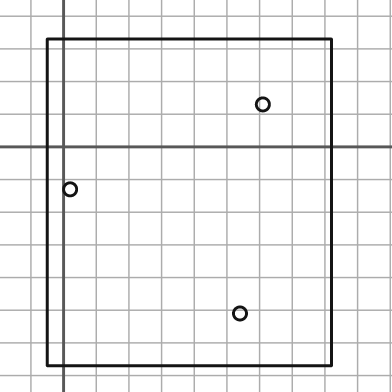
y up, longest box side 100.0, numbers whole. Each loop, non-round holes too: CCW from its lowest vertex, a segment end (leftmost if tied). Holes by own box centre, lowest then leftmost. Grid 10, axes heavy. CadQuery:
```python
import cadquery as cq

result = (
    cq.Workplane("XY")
    .moveTo(-5.0, -67.0)
    .lineTo(82.0, -67.0)
    .lineTo(82.0, 33.0)
    .lineTo(-5.0, 33.0)
    .close()
    .moveTo(54.0, -51.0)
    .circle(2.0)
    .moveTo(2.0, -13.0)
    .circle(2.0)
    .moveTo(61.0, 13.0)
    .circle(2.0)
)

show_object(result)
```